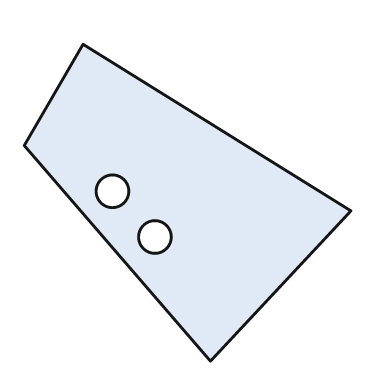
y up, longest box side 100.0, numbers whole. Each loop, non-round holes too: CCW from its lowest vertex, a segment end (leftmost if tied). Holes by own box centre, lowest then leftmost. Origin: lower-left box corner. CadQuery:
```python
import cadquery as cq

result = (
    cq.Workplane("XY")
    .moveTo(57.0, 0.0)
    .lineTo(100.0, 46.0)
    .lineTo(18.0, 97.0)
    .lineTo(0.0, 66.0)
    .close()
    .moveTo(40.0, 38.0)
    .circle(5.0)
    .moveTo(27.0, 52.0)
    .circle(5.0)
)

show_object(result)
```